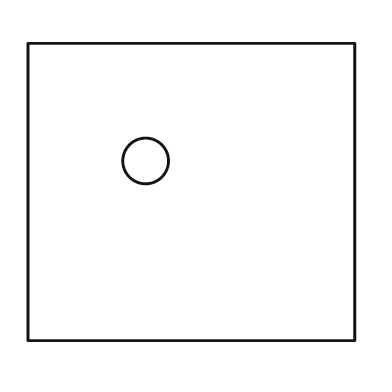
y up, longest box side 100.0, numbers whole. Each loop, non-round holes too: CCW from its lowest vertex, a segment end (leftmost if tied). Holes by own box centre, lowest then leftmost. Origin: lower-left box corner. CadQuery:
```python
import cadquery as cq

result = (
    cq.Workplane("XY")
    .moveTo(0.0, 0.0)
    .lineTo(100.0, 0.0)
    .lineTo(100.0, 91.0)
    .lineTo(0.0, 91.0)
    .close()
    .moveTo(36.0, 55.0)
    .circle(7.0)
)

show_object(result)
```